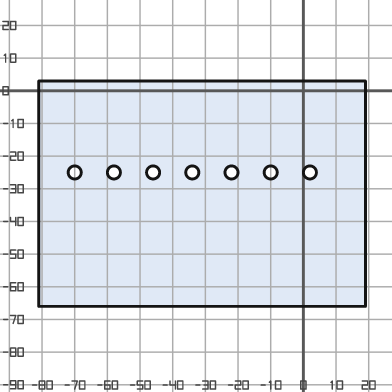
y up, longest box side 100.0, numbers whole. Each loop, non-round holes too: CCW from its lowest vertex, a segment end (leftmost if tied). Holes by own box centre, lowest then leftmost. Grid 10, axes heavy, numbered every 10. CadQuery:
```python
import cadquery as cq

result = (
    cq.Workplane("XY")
    .moveTo(-81.0, -66.0)
    .lineTo(19.0, -66.0)
    .lineTo(19.0, 3.0)
    .lineTo(-81.0, 3.0)
    .close()
    .moveTo(-70.0, -25.0)
    .circle(2.0)
    .moveTo(-58.0, -25.0)
    .circle(2.0)
    .moveTo(-46.0, -25.0)
    .circle(2.0)
    .moveTo(-34.0, -25.0)
    .circle(2.0)
    .moveTo(-22.0, -25.0)
    .circle(2.0)
    .moveTo(-10.0, -25.0)
    .circle(2.0)
    .moveTo(2.0, -25.0)
    .circle(2.0)
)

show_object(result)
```